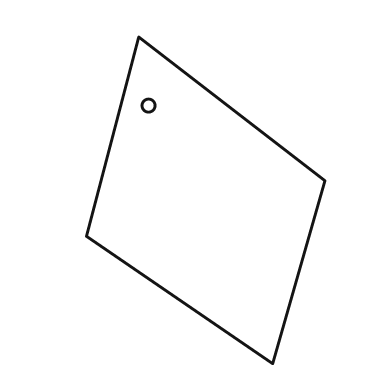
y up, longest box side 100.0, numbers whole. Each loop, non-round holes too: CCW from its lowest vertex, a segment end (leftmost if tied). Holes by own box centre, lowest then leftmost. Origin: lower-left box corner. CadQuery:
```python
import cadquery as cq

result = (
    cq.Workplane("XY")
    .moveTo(57.0, 0.0)
    .lineTo(73.0, 56.0)
    .lineTo(16.0, 100.0)
    .lineTo(0.0, 39.0)
    .close()
    .moveTo(19.0, 79.0)
    .circle(2.0)
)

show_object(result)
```